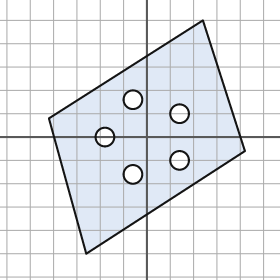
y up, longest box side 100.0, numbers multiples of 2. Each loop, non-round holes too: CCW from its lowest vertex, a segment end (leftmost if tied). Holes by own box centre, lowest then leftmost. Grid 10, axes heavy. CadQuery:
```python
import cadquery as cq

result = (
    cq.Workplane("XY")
    .moveTo(-26.0, -50.0)
    .lineTo(42.0, -6.0)
    .lineTo(24.0, 50.0)
    .lineTo(-42.0, 8.0)
    .close()
    .moveTo(-6.0, -16.0)
    .circle(4.0)
    .moveTo(14.0, -10.0)
    .circle(4.0)
    .moveTo(-18.0, 0.0)
    .circle(4.0)
    .moveTo(14.0, 10.0)
    .circle(4.0)
    .moveTo(-6.0, 16.0)
    .circle(4.0)
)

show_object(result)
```